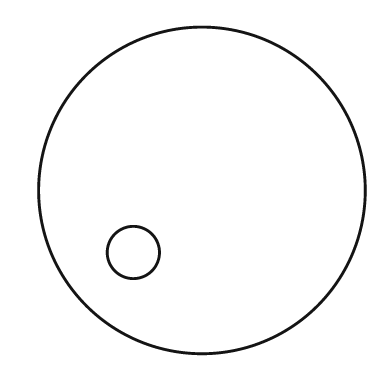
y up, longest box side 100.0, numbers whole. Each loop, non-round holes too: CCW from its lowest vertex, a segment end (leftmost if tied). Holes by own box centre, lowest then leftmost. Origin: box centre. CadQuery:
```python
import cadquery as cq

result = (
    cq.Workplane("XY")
    .moveTo(0.0, 0.0)
    .circle(50.0)
    .moveTo(-21.0, -19.0)
    .circle(8.0)
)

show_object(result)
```